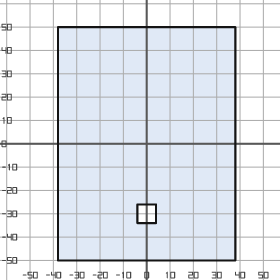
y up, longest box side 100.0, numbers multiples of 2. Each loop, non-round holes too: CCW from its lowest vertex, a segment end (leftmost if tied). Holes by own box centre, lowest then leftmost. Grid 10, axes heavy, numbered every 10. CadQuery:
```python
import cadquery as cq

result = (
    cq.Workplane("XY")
    .moveTo(-38.0, -50.0)
    .lineTo(38.0, -50.0)
    .lineTo(38.0, 50.0)
    .lineTo(-38.0, 50.0)
    .close()
    .moveTo(-4.0, -34.0)
    .lineTo(4.0, -34.0)
    .lineTo(4.0, -26.0)
    .lineTo(-4.0, -26.0)
    .close()
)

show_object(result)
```